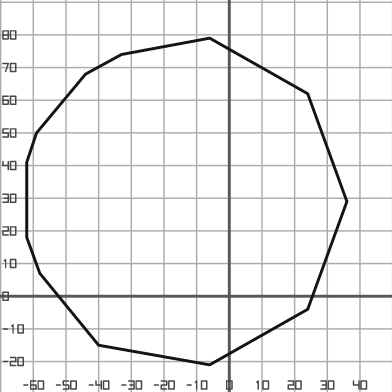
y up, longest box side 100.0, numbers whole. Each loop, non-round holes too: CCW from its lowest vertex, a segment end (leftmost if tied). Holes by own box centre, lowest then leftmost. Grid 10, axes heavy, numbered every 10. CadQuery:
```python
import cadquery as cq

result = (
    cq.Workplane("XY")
    .moveTo(-6.0, -21.0)
    .lineTo(24.0, -4.0)
    .lineTo(36.0, 29.0)
    .lineTo(24.0, 62.0)
    .lineTo(-6.0, 79.0)
    .lineTo(-33.0, 74.0)
    .lineTo(-44.0, 68.0)
    .lineTo(-59.0, 50.0)
    .lineTo(-62.0, 41.0)
    .lineTo(-62.0, 18.0)
    .lineTo(-58.0, 7.0)
    .lineTo(-40.0, -15.0)
    .close()
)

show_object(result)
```